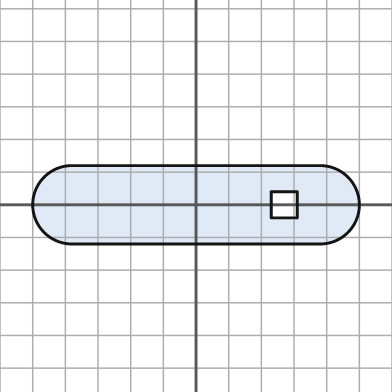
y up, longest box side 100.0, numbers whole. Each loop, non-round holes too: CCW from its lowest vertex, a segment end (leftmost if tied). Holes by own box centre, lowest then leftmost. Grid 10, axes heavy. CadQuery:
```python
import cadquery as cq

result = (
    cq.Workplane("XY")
    .moveTo(-38.0, -12.0)
    .lineTo(38.0, -12.0)
    .threePointArc((50.0, 0.0), (38.0, 12.0))
    .lineTo(-38.0, 12.0)
    .threePointArc((-50.0, 0.0), (-38.0, -12.0))
    .close()
    .moveTo(23.0, -4.0)
    .lineTo(31.0, -4.0)
    .lineTo(31.0, 4.0)
    .lineTo(23.0, 4.0)
    .close()
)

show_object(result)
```